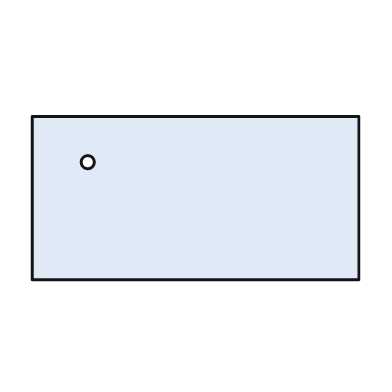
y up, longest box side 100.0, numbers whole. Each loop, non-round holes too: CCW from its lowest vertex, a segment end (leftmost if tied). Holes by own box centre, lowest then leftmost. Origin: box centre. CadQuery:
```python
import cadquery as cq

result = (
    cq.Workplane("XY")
    .moveTo(-50.0, -25.0)
    .lineTo(50.0, -25.0)
    .lineTo(50.0, 25.0)
    .lineTo(-50.0, 25.0)
    .close()
    .moveTo(-33.0, 11.0)
    .circle(2.0)
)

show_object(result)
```